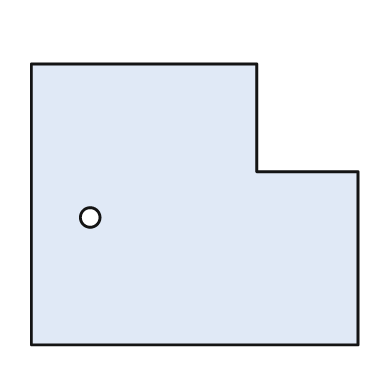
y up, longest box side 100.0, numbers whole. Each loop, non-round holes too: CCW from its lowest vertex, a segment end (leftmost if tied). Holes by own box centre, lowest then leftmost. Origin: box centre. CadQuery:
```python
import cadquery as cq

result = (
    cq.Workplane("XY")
    .moveTo(-50.0, -43.0)
    .lineTo(50.0, -43.0)
    .lineTo(50.0, 10.0)
    .lineTo(19.0, 10.0)
    .lineTo(19.0, 43.0)
    .lineTo(-50.0, 43.0)
    .close()
    .moveTo(-32.0, -4.0)
    .circle(3.0)
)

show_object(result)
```